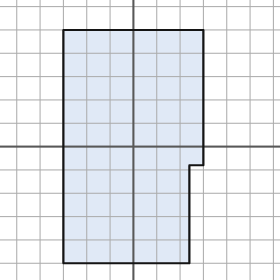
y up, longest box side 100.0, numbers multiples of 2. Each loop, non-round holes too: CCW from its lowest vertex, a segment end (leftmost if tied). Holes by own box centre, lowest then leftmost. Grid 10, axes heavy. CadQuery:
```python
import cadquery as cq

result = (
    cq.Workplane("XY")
    .moveTo(-30.0, -50.0)
    .lineTo(24.0, -50.0)
    .lineTo(24.0, -8.0)
    .lineTo(30.0, -8.0)
    .lineTo(30.0, 50.0)
    .lineTo(-30.0, 50.0)
    .close()
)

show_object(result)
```